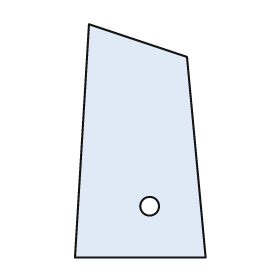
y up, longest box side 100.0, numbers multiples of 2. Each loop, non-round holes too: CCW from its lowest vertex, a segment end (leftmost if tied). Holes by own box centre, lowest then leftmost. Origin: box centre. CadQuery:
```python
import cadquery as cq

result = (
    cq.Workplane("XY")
    .moveTo(-28.0, -50.0)
    .lineTo(28.0, -50.0)
    .lineTo(20.0, 36.0)
    .lineTo(-22.0, 50.0)
    .close()
    .moveTo(4.0, -28.0)
    .circle(4.0)
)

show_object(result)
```